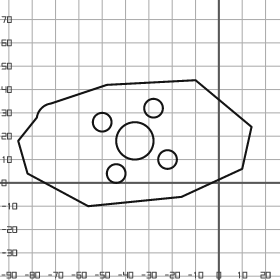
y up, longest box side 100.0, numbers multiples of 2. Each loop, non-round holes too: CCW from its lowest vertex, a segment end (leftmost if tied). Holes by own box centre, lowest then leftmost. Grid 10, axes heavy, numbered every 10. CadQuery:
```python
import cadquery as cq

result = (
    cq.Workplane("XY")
    .moveTo(-56.0, -10.0)
    .lineTo(-16.0, -6.0)
    .lineTo(10.0, 6.0)
    .lineTo(14.0, 24.0)
    .lineTo(-10.0, 44.0)
    .lineTo(-48.0, 42.0)
    .lineTo(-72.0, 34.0)
    .threePointArc((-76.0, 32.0), (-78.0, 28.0))
    .lineTo(-86.0, 18.0)
    .lineTo(-82.0, 4.0)
    .close()
    .moveTo(-44.0, 4.0)
    .circle(4.0)
    .moveTo(-22.0, 10.0)
    .circle(4.0)
    .moveTo(-36.0, 18.0)
    .circle(8.0)
    .moveTo(-50.0, 26.0)
    .circle(4.0)
    .moveTo(-28.0, 32.0)
    .circle(4.0)
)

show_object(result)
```